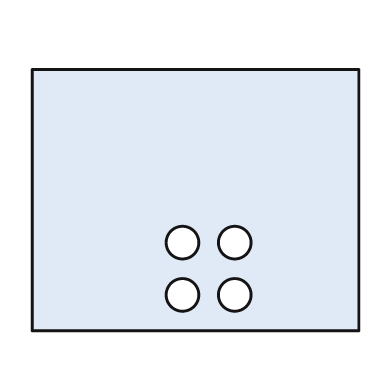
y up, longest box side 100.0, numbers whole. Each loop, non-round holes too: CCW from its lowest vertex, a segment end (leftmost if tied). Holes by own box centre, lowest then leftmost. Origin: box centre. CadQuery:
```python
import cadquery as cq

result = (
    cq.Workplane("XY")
    .moveTo(-50.0, -40.0)
    .lineTo(50.0, -40.0)
    .lineTo(50.0, 40.0)
    .lineTo(-50.0, 40.0)
    .close()
    .moveTo(-4.0, -29.0)
    .circle(5.0)
    .moveTo(12.0, -29.0)
    .circle(5.0)
    .moveTo(-4.0, -13.0)
    .circle(5.0)
    .moveTo(12.0, -13.0)
    .circle(5.0)
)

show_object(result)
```